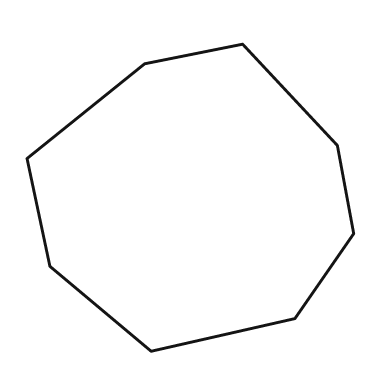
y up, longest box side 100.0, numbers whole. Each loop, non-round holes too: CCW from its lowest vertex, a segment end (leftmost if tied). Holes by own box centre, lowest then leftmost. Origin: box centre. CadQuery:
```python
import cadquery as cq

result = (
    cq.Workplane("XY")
    .moveTo(-12.0, -47.0)
    .lineTo(32.0, -37.0)
    .lineTo(50.0, -11.0)
    .lineTo(45.0, 16.0)
    .lineTo(16.0, 47.0)
    .lineTo(-14.0, 41.0)
    .lineTo(-50.0, 12.0)
    .lineTo(-43.0, -21.0)
    .close()
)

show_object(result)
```